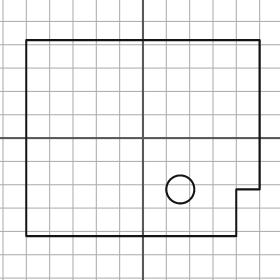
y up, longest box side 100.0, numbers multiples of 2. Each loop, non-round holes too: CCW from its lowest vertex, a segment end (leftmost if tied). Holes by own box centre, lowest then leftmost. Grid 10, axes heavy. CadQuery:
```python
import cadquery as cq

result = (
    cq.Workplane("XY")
    .moveTo(-50.0, -42.0)
    .lineTo(40.0, -42.0)
    .lineTo(40.0, -22.0)
    .lineTo(50.0, -22.0)
    .lineTo(50.0, 42.0)
    .lineTo(-50.0, 42.0)
    .close()
    .moveTo(16.0, -22.0)
    .circle(6.0)
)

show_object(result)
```